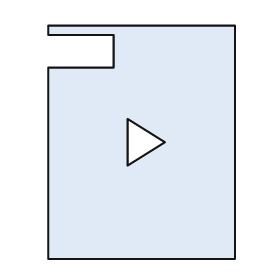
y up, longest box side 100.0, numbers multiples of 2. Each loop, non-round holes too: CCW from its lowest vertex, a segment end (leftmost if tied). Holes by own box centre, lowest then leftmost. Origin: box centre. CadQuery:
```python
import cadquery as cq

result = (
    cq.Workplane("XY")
    .moveTo(-40.0, -50.0)
    .lineTo(40.0, -50.0)
    .lineTo(40.0, 50.0)
    .lineTo(-40.0, 50.0)
    .lineTo(-40.0, 46.0)
    .lineTo(-12.0, 46.0)
    .lineTo(-12.0, 32.0)
    .lineTo(-40.0, 32.0)
    .close()
    .moveTo(-6.0, -10.0)
    .lineTo(10.0, 0.0)
    .lineTo(-6.0, 10.0)
    .close()
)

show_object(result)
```